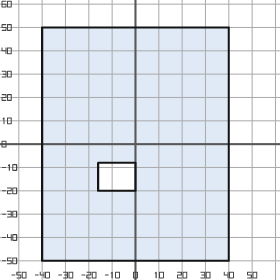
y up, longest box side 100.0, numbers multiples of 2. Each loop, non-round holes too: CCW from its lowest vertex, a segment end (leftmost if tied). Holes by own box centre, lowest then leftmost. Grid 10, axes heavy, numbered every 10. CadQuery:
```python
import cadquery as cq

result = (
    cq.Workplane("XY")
    .moveTo(-40.0, -50.0)
    .lineTo(40.0, -50.0)
    .lineTo(40.0, 50.0)
    .lineTo(-40.0, 50.0)
    .close()
    .moveTo(-16.0, -20.0)
    .lineTo(0.0, -20.0)
    .lineTo(0.0, -8.0)
    .lineTo(-16.0, -8.0)
    .close()
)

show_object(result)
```